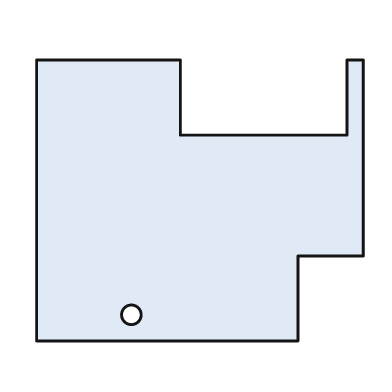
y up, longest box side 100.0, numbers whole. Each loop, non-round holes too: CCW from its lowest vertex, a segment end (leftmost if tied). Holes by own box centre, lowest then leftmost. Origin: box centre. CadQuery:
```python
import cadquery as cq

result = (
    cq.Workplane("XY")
    .moveTo(-50.0, -43.0)
    .lineTo(30.0, -43.0)
    .lineTo(30.0, -17.0)
    .lineTo(50.0, -17.0)
    .lineTo(50.0, 43.0)
    .lineTo(45.0, 43.0)
    .lineTo(45.0, 20.0)
    .lineTo(-6.0, 20.0)
    .lineTo(-6.0, 43.0)
    .lineTo(-50.0, 43.0)
    .close()
    .moveTo(-21.0, -35.0)
    .circle(3.0)
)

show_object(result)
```